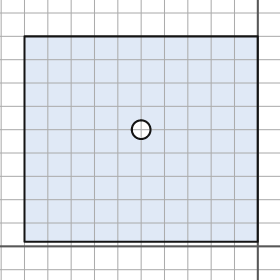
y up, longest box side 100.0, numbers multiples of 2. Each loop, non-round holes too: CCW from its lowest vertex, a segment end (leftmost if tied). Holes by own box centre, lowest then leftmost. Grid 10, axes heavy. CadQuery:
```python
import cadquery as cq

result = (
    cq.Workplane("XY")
    .moveTo(-100.0, 2.0)
    .lineTo(0.0, 2.0)
    .lineTo(0.0, 90.0)
    .lineTo(-100.0, 90.0)
    .close()
    .moveTo(-50.0, 50.0)
    .circle(4.0)
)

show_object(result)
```